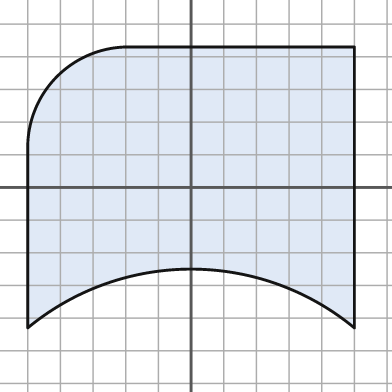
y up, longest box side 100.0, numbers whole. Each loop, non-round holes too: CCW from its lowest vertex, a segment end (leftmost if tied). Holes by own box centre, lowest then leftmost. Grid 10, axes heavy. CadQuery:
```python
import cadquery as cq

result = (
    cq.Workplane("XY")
    .moveTo(-50.0, -43.0)
    .threePointArc((0.0, -25.0), (50.0, -43.0))
    .lineTo(50.0, 43.0)
    .lineTo(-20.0, 43.0)
    .threePointArc((-41.0, 34.0), (-50.0, 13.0))
    .close()
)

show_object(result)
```